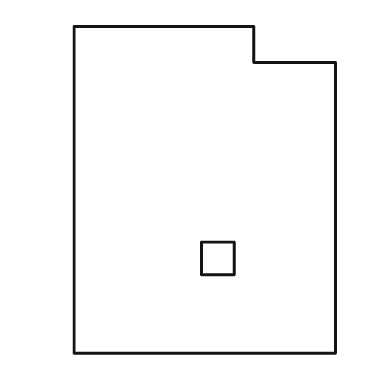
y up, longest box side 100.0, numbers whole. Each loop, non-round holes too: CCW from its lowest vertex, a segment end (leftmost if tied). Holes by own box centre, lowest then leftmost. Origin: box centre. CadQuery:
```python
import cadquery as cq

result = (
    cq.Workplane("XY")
    .moveTo(-40.0, -50.0)
    .lineTo(40.0, -50.0)
    .lineTo(40.0, 39.0)
    .lineTo(15.0, 39.0)
    .lineTo(15.0, 50.0)
    .lineTo(-40.0, 50.0)
    .close()
    .moveTo(-1.0, -26.0)
    .lineTo(9.0, -26.0)
    .lineTo(9.0, -16.0)
    .lineTo(-1.0, -16.0)
    .close()
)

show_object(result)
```